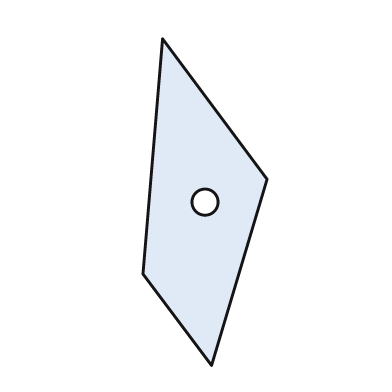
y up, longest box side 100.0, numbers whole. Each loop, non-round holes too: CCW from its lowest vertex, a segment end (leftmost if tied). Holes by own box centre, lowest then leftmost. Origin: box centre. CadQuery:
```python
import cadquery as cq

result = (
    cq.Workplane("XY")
    .moveTo(2.0, -50.0)
    .lineTo(19.0, 7.0)
    .lineTo(-13.0, 50.0)
    .lineTo(-19.0, -22.0)
    .close()
    .moveTo(0.0, 0.0)
    .circle(4.0)
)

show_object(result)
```